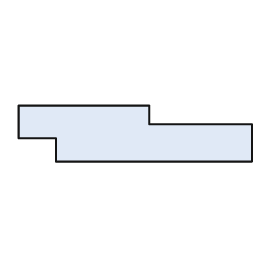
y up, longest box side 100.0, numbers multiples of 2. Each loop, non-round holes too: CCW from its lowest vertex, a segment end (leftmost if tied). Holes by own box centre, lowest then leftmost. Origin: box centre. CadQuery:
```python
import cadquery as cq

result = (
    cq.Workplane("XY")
    .moveTo(-34.0, -12.0)
    .lineTo(50.0, -12.0)
    .lineTo(50.0, 4.0)
    .lineTo(6.0, 4.0)
    .lineTo(6.0, 12.0)
    .lineTo(-50.0, 12.0)
    .lineTo(-50.0, -2.0)
    .lineTo(-34.0, -2.0)
    .close()
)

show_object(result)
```